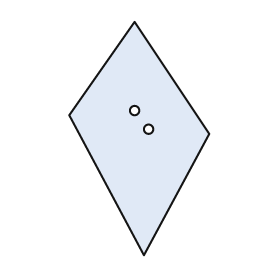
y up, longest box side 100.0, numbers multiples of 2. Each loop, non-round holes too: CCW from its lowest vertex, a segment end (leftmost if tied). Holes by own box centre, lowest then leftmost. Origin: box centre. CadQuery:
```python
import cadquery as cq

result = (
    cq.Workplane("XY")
    .moveTo(2.0, -50.0)
    .lineTo(30.0, 2.0)
    .lineTo(-2.0, 50.0)
    .lineTo(-30.0, 10.0)
    .close()
    .moveTo(4.0, 4.0)
    .circle(2.0)
    .moveTo(-2.0, 12.0)
    .circle(2.0)
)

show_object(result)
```